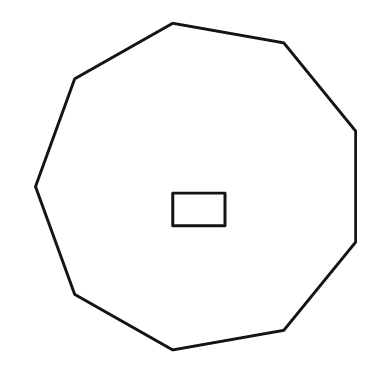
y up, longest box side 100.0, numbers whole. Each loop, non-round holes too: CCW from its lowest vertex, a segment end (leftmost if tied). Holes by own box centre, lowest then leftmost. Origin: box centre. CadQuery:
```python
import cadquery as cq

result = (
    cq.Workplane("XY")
    .moveTo(-7.0, -50.0)
    .lineTo(27.0, -44.0)
    .lineTo(49.0, -17.0)
    .lineTo(49.0, 17.0)
    .lineTo(27.0, 44.0)
    .lineTo(-7.0, 50.0)
    .lineTo(-37.0, 33.0)
    .lineTo(-49.0, 0.0)
    .lineTo(-37.0, -33.0)
    .close()
    .moveTo(-7.0, -12.0)
    .lineTo(9.0, -12.0)
    .lineTo(9.0, -2.0)
    .lineTo(-7.0, -2.0)
    .close()
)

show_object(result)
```